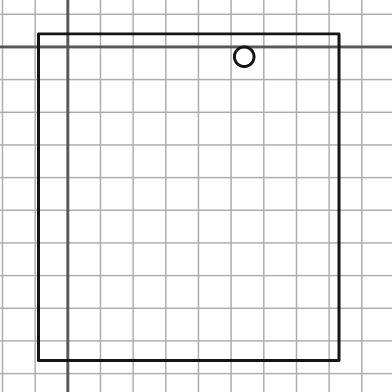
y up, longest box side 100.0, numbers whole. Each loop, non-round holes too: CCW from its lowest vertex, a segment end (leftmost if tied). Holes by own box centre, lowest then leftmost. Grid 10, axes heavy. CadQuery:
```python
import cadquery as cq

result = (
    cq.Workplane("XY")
    .moveTo(-9.0, -96.0)
    .lineTo(83.0, -96.0)
    .lineTo(83.0, 4.0)
    .lineTo(-9.0, 4.0)
    .close()
    .moveTo(54.0, -3.0)
    .circle(3.0)
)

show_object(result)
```